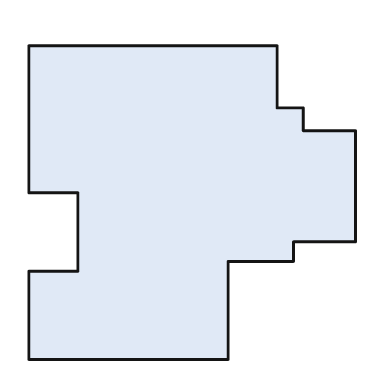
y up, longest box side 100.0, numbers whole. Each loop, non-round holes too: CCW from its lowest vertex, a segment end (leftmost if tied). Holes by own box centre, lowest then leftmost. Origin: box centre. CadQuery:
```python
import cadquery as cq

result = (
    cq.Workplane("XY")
    .moveTo(-50.0, -48.0)
    .lineTo(11.0, -48.0)
    .lineTo(11.0, -18.0)
    .lineTo(31.0, -18.0)
    .lineTo(31.0, -12.0)
    .lineTo(50.0, -12.0)
    .lineTo(50.0, 22.0)
    .lineTo(34.0, 22.0)
    .lineTo(34.0, 29.0)
    .lineTo(26.0, 29.0)
    .lineTo(26.0, 48.0)
    .lineTo(-50.0, 48.0)
    .lineTo(-50.0, 3.0)
    .lineTo(-35.0, 3.0)
    .lineTo(-35.0, -21.0)
    .lineTo(-50.0, -21.0)
    .close()
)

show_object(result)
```